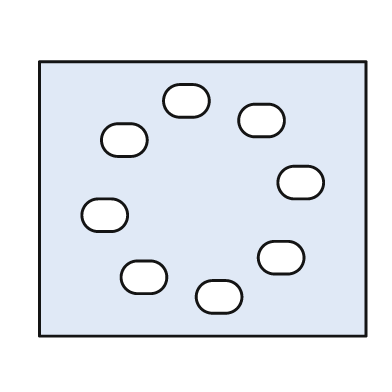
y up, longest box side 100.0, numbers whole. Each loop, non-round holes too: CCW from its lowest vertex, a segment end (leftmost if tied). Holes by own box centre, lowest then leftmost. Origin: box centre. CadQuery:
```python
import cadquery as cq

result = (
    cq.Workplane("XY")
    .moveTo(-50.0, -42.0)
    .lineTo(50.0, -42.0)
    .lineTo(50.0, 42.0)
    .lineTo(-50.0, 42.0)
    .close()
    .moveTo(3.0, -35.0)
    .lineTo(7.0, -35.0)
    .threePointArc((12.0, -30.0), (7.0, -25.0))
    .lineTo(3.0, -25.0)
    .threePointArc((-2.0, -30.0), (3.0, -35.0))
    .close()
    .moveTo(-20.0, -29.0)
    .lineTo(-16.0, -29.0)
    .threePointArc((-11.0, -24.0), (-16.0, -19.0))
    .lineTo(-20.0, -19.0)
    .threePointArc((-25.0, -24.0), (-20.0, -29.0))
    .close()
    .moveTo(22.0, -23.0)
    .lineTo(26.0, -23.0)
    .threePointArc((31.0, -18.0), (26.0, -13.0))
    .lineTo(22.0, -13.0)
    .threePointArc((17.0, -18.0), (22.0, -23.0))
    .close()
    .moveTo(-32.0, -10.0)
    .lineTo(-28.0, -10.0)
    .threePointArc((-23.0, -5.0), (-28.0, 0.0))
    .lineTo(-32.0, 0.0)
    .threePointArc((-37.0, -5.0), (-32.0, -10.0))
    .close()
    .moveTo(28.0, 0.0)
    .lineTo(32.0, 0.0)
    .threePointArc((37.0, 5.0), (32.0, 10.0))
    .lineTo(28.0, 10.0)
    .threePointArc((23.0, 5.0), (28.0, 0.0))
    .close()
    .moveTo(-26.0, 13.0)
    .lineTo(-22.0, 13.0)
    .threePointArc((-17.0, 18.0), (-22.0, 23.0))
    .lineTo(-26.0, 23.0)
    .threePointArc((-31.0, 18.0), (-26.0, 13.0))
    .close()
    .moveTo(16.0, 19.0)
    .lineTo(20.0, 19.0)
    .threePointArc((25.0, 24.0), (20.0, 29.0))
    .lineTo(16.0, 29.0)
    .threePointArc((11.0, 24.0), (16.0, 19.0))
    .close()
    .moveTo(-7.0, 25.0)
    .lineTo(-3.0, 25.0)
    .threePointArc((2.0, 30.0), (-3.0, 35.0))
    .lineTo(-7.0, 35.0)
    .threePointArc((-12.0, 30.0), (-7.0, 25.0))
    .close()
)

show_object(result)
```